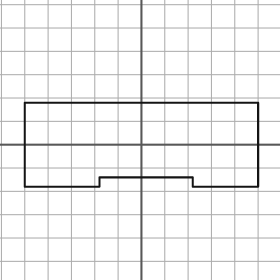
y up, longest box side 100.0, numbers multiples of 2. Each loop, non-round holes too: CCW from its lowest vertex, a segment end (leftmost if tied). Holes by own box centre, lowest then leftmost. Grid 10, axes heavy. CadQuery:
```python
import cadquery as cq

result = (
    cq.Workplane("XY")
    .moveTo(-50.0, -18.0)
    .lineTo(-18.0, -18.0)
    .lineTo(-18.0, -14.0)
    .lineTo(22.0, -14.0)
    .lineTo(22.0, -18.0)
    .lineTo(50.0, -18.0)
    .lineTo(50.0, 18.0)
    .lineTo(-50.0, 18.0)
    .close()
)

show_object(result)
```